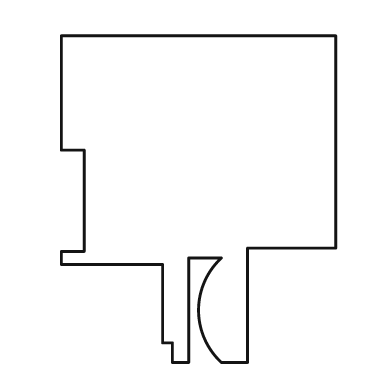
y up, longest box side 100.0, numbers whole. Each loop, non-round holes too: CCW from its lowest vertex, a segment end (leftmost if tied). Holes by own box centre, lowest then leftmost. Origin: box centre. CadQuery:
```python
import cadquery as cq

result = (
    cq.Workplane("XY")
    .moveTo(-8.0, -50.0)
    .lineTo(-3.0, -50.0)
    .lineTo(-3.0, -18.0)
    .lineTo(7.0, -18.0)
    .threePointArc((0.0, -34.0), (7.0, -50.0))
    .lineTo(15.0, -50.0)
    .lineTo(15.0, -15.0)
    .lineTo(42.0, -15.0)
    .lineTo(42.0, 50.0)
    .lineTo(-42.0, 50.0)
    .lineTo(-42.0, 15.0)
    .lineTo(-35.0, 15.0)
    .lineTo(-35.0, -16.0)
    .lineTo(-42.0, -16.0)
    .lineTo(-42.0, -20.0)
    .lineTo(-11.0, -20.0)
    .lineTo(-11.0, -44.0)
    .lineTo(-8.0, -44.0)
    .close()
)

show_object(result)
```